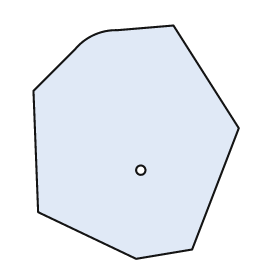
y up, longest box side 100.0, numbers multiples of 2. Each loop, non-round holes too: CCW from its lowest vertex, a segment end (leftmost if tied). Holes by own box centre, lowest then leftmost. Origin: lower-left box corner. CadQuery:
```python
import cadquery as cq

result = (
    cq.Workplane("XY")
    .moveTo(44.0, 0.0)
    .lineTo(68.0, 4.0)
    .lineTo(88.0, 56.0)
    .lineTo(60.0, 100.0)
    .lineTo(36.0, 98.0)
    .threePointArc((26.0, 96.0), (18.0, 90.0))
    .lineTo(0.0, 72.0)
    .lineTo(2.0, 20.0)
    .close()
    .moveTo(46.0, 38.0)
    .circle(2.0)
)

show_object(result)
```